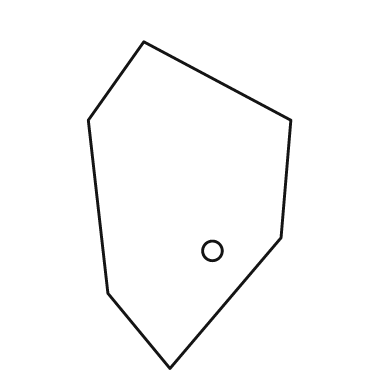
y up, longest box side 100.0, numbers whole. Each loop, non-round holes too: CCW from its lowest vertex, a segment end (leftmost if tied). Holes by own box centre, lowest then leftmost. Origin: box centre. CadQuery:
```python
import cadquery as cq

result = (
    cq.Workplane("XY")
    .moveTo(-6.0, -50.0)
    .lineTo(28.0, -10.0)
    .lineTo(31.0, 26.0)
    .lineTo(-14.0, 50.0)
    .lineTo(-31.0, 26.0)
    .lineTo(-25.0, -27.0)
    .close()
    .moveTo(7.0, -14.0)
    .circle(3.0)
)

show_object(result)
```